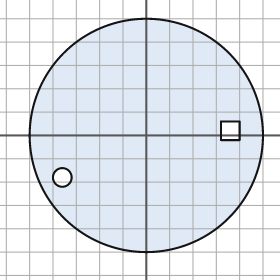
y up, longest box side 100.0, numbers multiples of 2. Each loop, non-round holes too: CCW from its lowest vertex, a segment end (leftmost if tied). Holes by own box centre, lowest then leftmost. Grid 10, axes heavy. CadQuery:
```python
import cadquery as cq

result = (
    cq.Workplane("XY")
    .moveTo(0.0, 0.0)
    .circle(50.0)
    .moveTo(-36.0, -18.0)
    .circle(4.0)
    .moveTo(32.0, -2.0)
    .lineTo(40.0, -2.0)
    .lineTo(40.0, 6.0)
    .lineTo(32.0, 6.0)
    .close()
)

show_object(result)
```